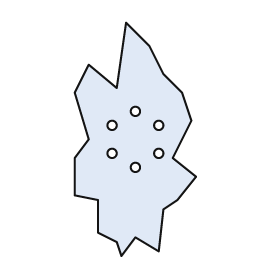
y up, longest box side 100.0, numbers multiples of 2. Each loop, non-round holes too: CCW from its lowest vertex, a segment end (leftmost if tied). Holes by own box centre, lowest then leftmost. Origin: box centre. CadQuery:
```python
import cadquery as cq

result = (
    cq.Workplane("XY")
    .moveTo(-6.0, -50.0)
    .lineTo(0.0, -42.0)
    .lineTo(10.0, -48.0)
    .lineTo(12.0, -30.0)
    .lineTo(18.0, -26.0)
    .lineTo(26.0, -16.0)
    .lineTo(16.0, -8.0)
    .lineTo(24.0, 8.0)
    .lineTo(20.0, 20.0)
    .lineTo(12.0, 28.0)
    .lineTo(6.0, 40.0)
    .lineTo(-4.0, 50.0)
    .lineTo(-8.0, 22.0)
    .lineTo(-20.0, 32.0)
    .lineTo(-26.0, 20.0)
    .lineTo(-20.0, 0.0)
    .lineTo(-26.0, -8.0)
    .lineTo(-26.0, -24.0)
    .lineTo(-16.0, -26.0)
    .lineTo(-16.0, -40.0)
    .lineTo(-8.0, -44.0)
    .close()
    .moveTo(0.0, -12.0)
    .circle(2.0)
    .moveTo(-10.0, -6.0)
    .circle(2.0)
    .moveTo(10.0, -6.0)
    .circle(2.0)
    .moveTo(-10.0, 6.0)
    .circle(2.0)
    .moveTo(10.0, 6.0)
    .circle(2.0)
    .moveTo(0.0, 12.0)
    .circle(2.0)
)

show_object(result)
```